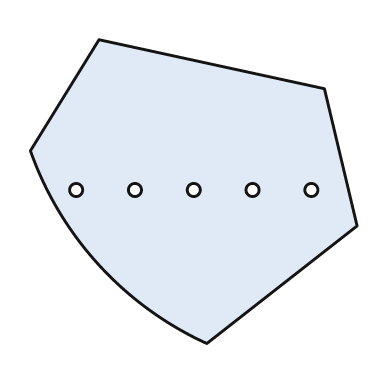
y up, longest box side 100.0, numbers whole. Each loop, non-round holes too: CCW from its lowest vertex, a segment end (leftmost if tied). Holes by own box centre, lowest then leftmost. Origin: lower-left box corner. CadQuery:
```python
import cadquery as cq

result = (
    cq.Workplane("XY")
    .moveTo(54.0, 0.0)
    .lineTo(100.0, 36.0)
    .lineTo(90.0, 78.0)
    .lineTo(21.0, 93.0)
    .lineTo(0.0, 59.0)
    .threePointArc((21.0, 24.0), (54.0, 0.0))
    .close()
    .moveTo(14.0, 47.0)
    .circle(2.0)
    .moveTo(32.0, 47.0)
    .circle(2.0)
    .moveTo(50.0, 47.0)
    .circle(2.0)
    .moveTo(68.0, 47.0)
    .circle(2.0)
    .moveTo(86.0, 47.0)
    .circle(2.0)
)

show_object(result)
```